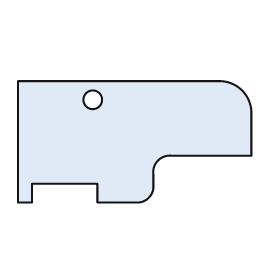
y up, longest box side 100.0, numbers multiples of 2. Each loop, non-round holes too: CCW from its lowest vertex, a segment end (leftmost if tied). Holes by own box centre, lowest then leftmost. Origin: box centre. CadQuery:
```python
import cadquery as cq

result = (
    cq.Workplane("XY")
    .moveTo(-50.0, -26.0)
    .lineTo(-44.0, -26.0)
    .lineTo(-44.0, -18.0)
    .lineTo(-16.0, -18.0)
    .lineTo(-16.0, -26.0)
    .lineTo(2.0, -26.0)
    .threePointArc((6.0, -24.0), (8.0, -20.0))
    .lineTo(8.0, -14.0)
    .threePointArc((10.0, -8.0), (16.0, -6.0))
    .lineTo(50.0, -6.0)
    .lineTo(50.0, 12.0)
    .threePointArc((46.0, 22.0), (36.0, 26.0))
    .lineTo(-50.0, 26.0)
    .close()
    .moveTo(-18.0, 18.0)
    .circle(4.0)
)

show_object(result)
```